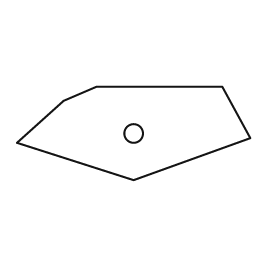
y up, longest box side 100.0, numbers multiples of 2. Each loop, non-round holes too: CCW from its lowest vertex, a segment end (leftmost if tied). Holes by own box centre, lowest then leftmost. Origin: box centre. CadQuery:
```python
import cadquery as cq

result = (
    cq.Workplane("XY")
    .moveTo(0.0, -20.0)
    .lineTo(50.0, -2.0)
    .lineTo(38.0, 20.0)
    .lineTo(-16.0, 20.0)
    .lineTo(-30.0, 14.0)
    .lineTo(-50.0, -4.0)
    .close()
    .moveTo(0.0, 0.0)
    .circle(4.0)
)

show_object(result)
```